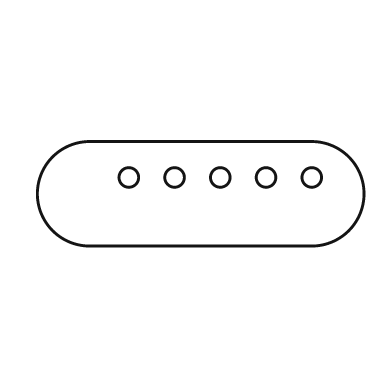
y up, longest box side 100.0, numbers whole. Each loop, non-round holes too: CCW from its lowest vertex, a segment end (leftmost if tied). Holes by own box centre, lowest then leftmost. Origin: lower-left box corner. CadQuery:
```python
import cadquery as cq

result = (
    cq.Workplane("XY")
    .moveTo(16.0, 0.0)
    .lineTo(84.0, 0.0)
    .threePointArc((100.0, 16.0), (84.0, 32.0))
    .lineTo(16.0, 32.0)
    .threePointArc((0.0, 16.0), (16.0, 0.0))
    .close()
    .moveTo(28.0, 21.0)
    .circle(3.0)
    .moveTo(42.0, 21.0)
    .circle(3.0)
    .moveTo(56.0, 21.0)
    .circle(3.0)
    .moveTo(70.0, 21.0)
    .circle(3.0)
    .moveTo(84.0, 21.0)
    .circle(3.0)
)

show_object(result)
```